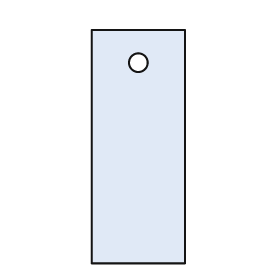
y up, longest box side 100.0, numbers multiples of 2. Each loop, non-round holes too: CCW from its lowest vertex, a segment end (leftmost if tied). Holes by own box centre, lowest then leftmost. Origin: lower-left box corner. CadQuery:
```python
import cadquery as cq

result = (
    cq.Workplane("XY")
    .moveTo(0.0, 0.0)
    .lineTo(40.0, 0.0)
    .lineTo(40.0, 100.0)
    .lineTo(0.0, 100.0)
    .close()
    .moveTo(20.0, 86.0)
    .circle(4.0)
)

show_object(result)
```